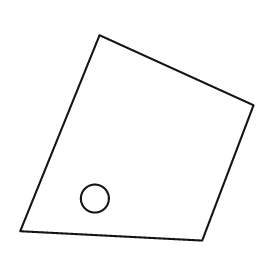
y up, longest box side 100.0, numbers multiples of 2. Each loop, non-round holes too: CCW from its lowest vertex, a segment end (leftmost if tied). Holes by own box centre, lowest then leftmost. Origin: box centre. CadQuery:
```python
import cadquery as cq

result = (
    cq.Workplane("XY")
    .moveTo(28.0, -44.0)
    .lineTo(50.0, 14.0)
    .lineTo(-16.0, 44.0)
    .lineTo(-50.0, -40.0)
    .close()
    .moveTo(-18.0, -26.0)
    .circle(6.0)
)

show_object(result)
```